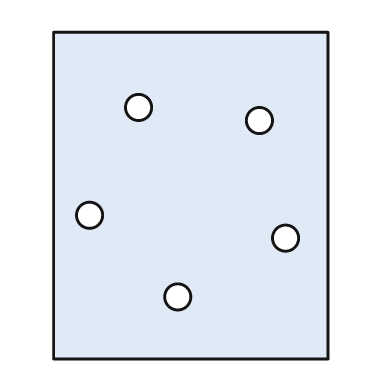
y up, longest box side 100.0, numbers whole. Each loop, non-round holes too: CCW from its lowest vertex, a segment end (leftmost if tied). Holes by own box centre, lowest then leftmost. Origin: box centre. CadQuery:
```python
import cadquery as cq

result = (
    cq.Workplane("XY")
    .moveTo(-42.0, -50.0)
    .lineTo(42.0, -50.0)
    .lineTo(42.0, 50.0)
    .lineTo(-42.0, 50.0)
    .close()
    .moveTo(-4.0, -31.0)
    .circle(4.0)
    .moveTo(29.0, -13.0)
    .circle(4.0)
    .moveTo(-31.0, -6.0)
    .circle(4.0)
    .moveTo(21.0, 23.0)
    .circle(4.0)
    .moveTo(-16.0, 27.0)
    .circle(4.0)
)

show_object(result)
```